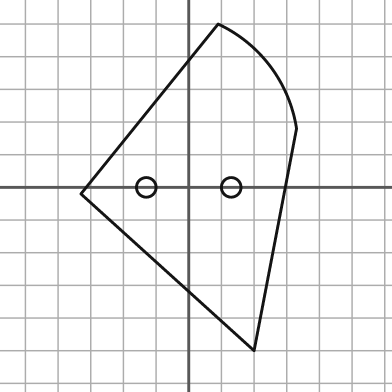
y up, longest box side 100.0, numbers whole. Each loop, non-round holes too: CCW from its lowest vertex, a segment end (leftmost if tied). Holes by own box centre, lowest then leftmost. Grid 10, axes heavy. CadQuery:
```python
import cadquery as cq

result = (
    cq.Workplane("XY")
    .moveTo(20.0, -50.0)
    .lineTo(33.0, 18.0)
    .threePointArc((25.0, 37.0), (9.0, 50.0))
    .lineTo(-33.0, -2.0)
    .close()
    .moveTo(-13.0, 0.0)
    .circle(3.0)
    .moveTo(13.0, 0.0)
    .circle(3.0)
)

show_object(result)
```